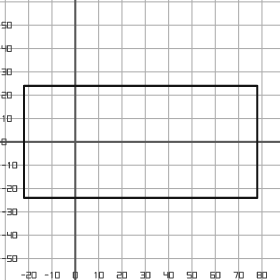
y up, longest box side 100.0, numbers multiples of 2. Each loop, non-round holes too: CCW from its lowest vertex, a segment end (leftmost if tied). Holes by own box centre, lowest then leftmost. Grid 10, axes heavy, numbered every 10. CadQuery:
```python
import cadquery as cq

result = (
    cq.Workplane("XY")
    .moveTo(-22.0, -24.0)
    .lineTo(78.0, -24.0)
    .lineTo(78.0, 24.0)
    .lineTo(-22.0, 24.0)
    .close()
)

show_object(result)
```